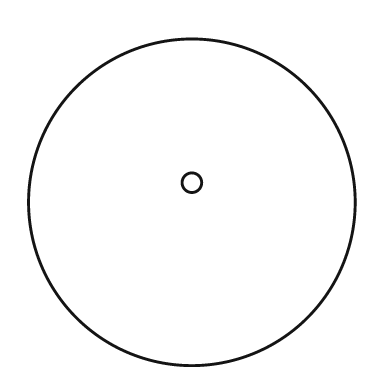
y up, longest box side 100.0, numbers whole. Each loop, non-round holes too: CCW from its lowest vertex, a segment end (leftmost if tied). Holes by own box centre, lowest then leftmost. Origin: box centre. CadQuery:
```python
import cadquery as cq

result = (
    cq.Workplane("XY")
    .moveTo(0.0, 0.0)
    .circle(50.0)
    .moveTo(0.0, 6.0)
    .circle(3.0)
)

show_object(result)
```